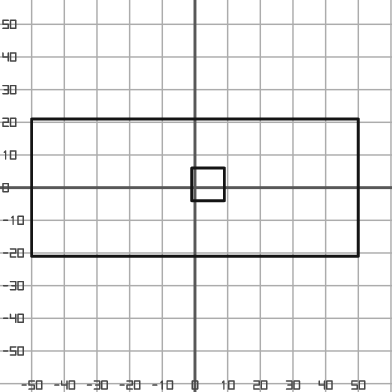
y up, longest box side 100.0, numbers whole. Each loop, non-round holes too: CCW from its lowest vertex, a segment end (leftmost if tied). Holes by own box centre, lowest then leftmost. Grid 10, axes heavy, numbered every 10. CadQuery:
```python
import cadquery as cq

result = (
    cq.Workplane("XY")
    .moveTo(-50.0, -21.0)
    .lineTo(50.0, -21.0)
    .lineTo(50.0, 21.0)
    .lineTo(-50.0, 21.0)
    .close()
    .moveTo(-1.0, -4.0)
    .lineTo(9.0, -4.0)
    .lineTo(9.0, 6.0)
    .lineTo(-1.0, 6.0)
    .close()
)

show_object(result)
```